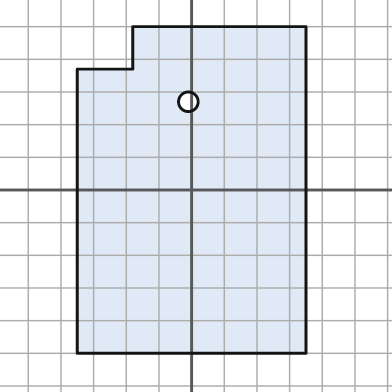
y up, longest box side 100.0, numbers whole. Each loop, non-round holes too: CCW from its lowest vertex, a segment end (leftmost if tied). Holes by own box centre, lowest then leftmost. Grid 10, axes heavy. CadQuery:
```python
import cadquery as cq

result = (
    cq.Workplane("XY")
    .moveTo(-35.0, -50.0)
    .lineTo(35.0, -50.0)
    .lineTo(35.0, 50.0)
    .lineTo(-18.0, 50.0)
    .lineTo(-18.0, 37.0)
    .lineTo(-35.0, 37.0)
    .close()
    .moveTo(-1.0, 27.0)
    .circle(3.0)
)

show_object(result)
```